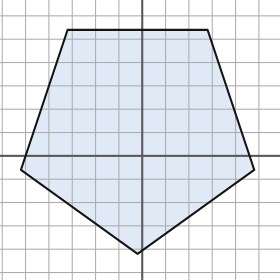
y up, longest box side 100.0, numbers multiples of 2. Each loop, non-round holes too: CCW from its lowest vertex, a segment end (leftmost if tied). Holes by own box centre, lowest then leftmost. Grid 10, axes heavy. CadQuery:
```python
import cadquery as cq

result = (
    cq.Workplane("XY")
    .moveTo(-2.0, -42.0)
    .lineTo(48.0, -6.0)
    .lineTo(28.0, 54.0)
    .lineTo(-32.0, 54.0)
    .lineTo(-52.0, -6.0)
    .close()
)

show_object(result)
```